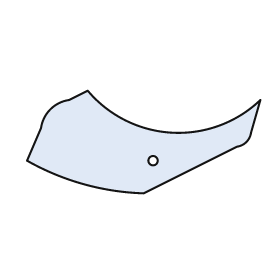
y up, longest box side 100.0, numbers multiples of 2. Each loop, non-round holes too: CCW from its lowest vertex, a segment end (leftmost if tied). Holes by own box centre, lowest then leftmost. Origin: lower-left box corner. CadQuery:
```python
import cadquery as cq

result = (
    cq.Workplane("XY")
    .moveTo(50.0, 0.0)
    .lineTo(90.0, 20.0)
    .threePointArc((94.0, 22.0), (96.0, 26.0))
    .lineTo(100.0, 40.0)
    .threePointArc((62.0, 26.0), (26.0, 44.0))
    .lineTo(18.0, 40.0)
    .threePointArc((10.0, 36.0), (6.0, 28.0))
    .lineTo(0.0, 14.0)
    .threePointArc((24.0, 4.0), (50.0, 0.0))
    .close()
    .moveTo(54.0, 14.0)
    .circle(2.0)
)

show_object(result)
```